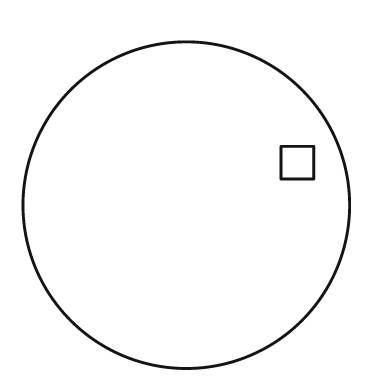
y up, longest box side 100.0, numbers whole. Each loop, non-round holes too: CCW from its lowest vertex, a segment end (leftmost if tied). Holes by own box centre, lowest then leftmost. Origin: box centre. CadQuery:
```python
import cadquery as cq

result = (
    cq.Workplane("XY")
    .moveTo(0.0, 0.0)
    .circle(50.0)
    .moveTo(29.0, 8.0)
    .lineTo(39.0, 8.0)
    .lineTo(39.0, 18.0)
    .lineTo(29.0, 18.0)
    .close()
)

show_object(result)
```